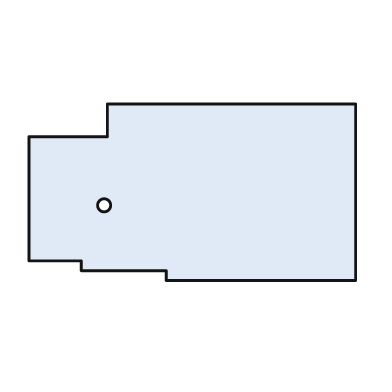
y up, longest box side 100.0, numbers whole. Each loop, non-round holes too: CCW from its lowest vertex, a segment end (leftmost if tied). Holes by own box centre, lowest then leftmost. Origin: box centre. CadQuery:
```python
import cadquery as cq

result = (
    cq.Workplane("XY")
    .moveTo(-8.0, -27.0)
    .lineTo(50.0, -27.0)
    .lineTo(50.0, 27.0)
    .lineTo(-26.0, 27.0)
    .lineTo(-26.0, 17.0)
    .lineTo(-50.0, 17.0)
    .lineTo(-50.0, -21.0)
    .lineTo(-34.0, -21.0)
    .lineTo(-34.0, -24.0)
    .lineTo(-8.0, -24.0)
    .close()
    .moveTo(-27.0, -4.0)
    .circle(2.0)
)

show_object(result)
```